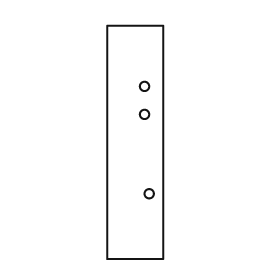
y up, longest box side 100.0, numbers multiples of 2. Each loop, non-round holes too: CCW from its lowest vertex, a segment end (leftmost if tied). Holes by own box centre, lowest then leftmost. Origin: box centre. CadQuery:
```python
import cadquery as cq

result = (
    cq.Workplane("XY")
    .moveTo(-12.0, -50.0)
    .lineTo(12.0, -50.0)
    .lineTo(12.0, 50.0)
    .lineTo(-12.0, 50.0)
    .close()
    .moveTo(6.0, -22.0)
    .circle(2.0)
    .moveTo(4.0, 12.0)
    .circle(2.0)
    .moveTo(4.0, 24.0)
    .circle(2.0)
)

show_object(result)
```